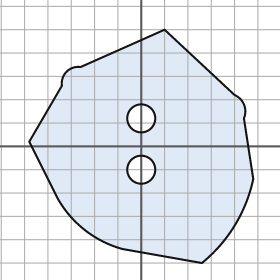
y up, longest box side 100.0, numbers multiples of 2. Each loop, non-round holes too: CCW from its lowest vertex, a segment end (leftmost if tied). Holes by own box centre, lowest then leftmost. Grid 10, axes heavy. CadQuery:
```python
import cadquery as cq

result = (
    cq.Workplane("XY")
    .moveTo(26.0, -50.0)
    .threePointArc((40.0, -34.0), (48.0, -14.0))
    .lineTo(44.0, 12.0)
    .threePointArc((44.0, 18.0), (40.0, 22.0))
    .lineTo(10.0, 50.0)
    .lineTo(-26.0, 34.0)
    .threePointArc((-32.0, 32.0), (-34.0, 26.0))
    .lineTo(-48.0, 2.0)
    .lineTo(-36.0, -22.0)
    .threePointArc((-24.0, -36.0), (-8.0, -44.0))
    .close()
    .moveTo(0.0, -10.0)
    .circle(6.0)
    .moveTo(0.0, 12.0)
    .circle(6.0)
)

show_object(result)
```